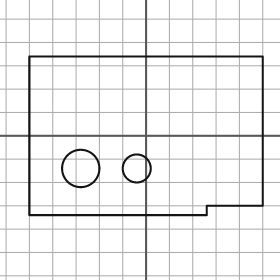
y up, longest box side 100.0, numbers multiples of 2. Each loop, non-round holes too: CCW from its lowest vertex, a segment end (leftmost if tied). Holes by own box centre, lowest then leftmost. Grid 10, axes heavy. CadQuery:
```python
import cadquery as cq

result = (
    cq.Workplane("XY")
    .moveTo(-50.0, -34.0)
    .lineTo(26.0, -34.0)
    .lineTo(26.0, -30.0)
    .lineTo(50.0, -30.0)
    .lineTo(50.0, 34.0)
    .lineTo(-50.0, 34.0)
    .close()
    .moveTo(-28.0, -14.0)
    .circle(8.0)
    .moveTo(-4.0, -14.0)
    .circle(6.0)
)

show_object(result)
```